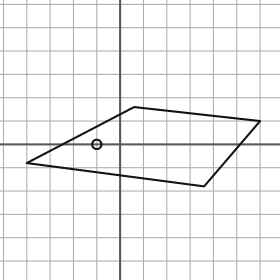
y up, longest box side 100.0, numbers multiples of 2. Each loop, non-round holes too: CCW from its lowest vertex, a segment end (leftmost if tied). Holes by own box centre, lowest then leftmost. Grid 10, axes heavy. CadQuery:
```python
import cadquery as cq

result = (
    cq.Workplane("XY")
    .moveTo(36.0, -18.0)
    .lineTo(60.0, 10.0)
    .lineTo(6.0, 16.0)
    .lineTo(-40.0, -8.0)
    .close()
    .moveTo(-10.0, 0.0)
    .circle(2.0)
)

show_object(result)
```